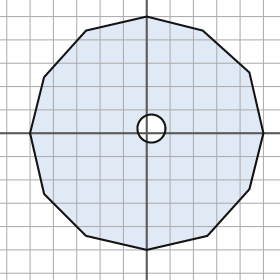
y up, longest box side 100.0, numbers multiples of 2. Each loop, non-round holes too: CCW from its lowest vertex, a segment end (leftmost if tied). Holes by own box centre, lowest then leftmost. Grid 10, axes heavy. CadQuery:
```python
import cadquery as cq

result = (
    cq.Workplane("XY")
    .moveTo(0.0, -50.0)
    .lineTo(26.0, -44.0)
    .lineTo(44.0, -24.0)
    .lineTo(50.0, 0.0)
    .lineTo(44.0, 26.0)
    .lineTo(24.0, 44.0)
    .lineTo(0.0, 50.0)
    .lineTo(-26.0, 44.0)
    .lineTo(-44.0, 24.0)
    .lineTo(-50.0, 0.0)
    .lineTo(-44.0, -26.0)
    .lineTo(-26.0, -44.0)
    .close()
    .moveTo(2.0, 2.0)
    .circle(6.0)
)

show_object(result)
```